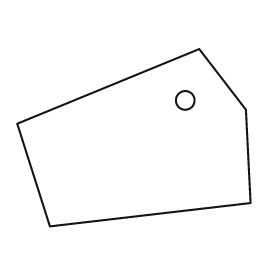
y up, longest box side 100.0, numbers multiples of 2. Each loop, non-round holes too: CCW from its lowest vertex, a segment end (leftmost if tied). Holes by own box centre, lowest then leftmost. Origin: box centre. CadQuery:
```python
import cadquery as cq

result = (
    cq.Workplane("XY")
    .moveTo(-36.0, -38.0)
    .lineTo(50.0, -28.0)
    .lineTo(48.0, 12.0)
    .lineTo(28.0, 38.0)
    .lineTo(-50.0, 6.0)
    .close()
    .moveTo(22.0, 16.0)
    .circle(4.0)
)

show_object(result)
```